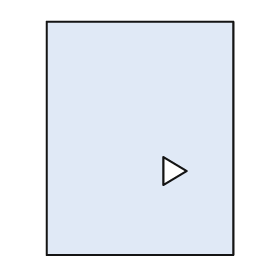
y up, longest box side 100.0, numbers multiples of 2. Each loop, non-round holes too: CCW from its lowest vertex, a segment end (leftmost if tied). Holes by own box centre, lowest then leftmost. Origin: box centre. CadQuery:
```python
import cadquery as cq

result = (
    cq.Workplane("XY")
    .moveTo(-40.0, -50.0)
    .lineTo(40.0, -50.0)
    .lineTo(40.0, 50.0)
    .lineTo(-40.0, 50.0)
    .close()
    .moveTo(10.0, -20.0)
    .lineTo(20.0, -14.0)
    .lineTo(10.0, -8.0)
    .close()
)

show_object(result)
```